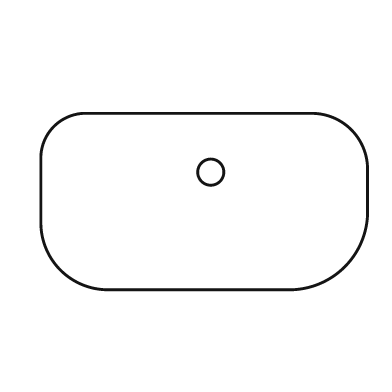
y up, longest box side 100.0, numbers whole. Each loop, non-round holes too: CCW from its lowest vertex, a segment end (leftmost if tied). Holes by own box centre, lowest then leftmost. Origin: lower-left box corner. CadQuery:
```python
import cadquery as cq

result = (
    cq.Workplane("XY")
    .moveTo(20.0, 0.0)
    .lineTo(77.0, 0.0)
    .threePointArc((93.0, 7.0), (100.0, 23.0))
    .lineTo(100.0, 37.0)
    .threePointArc((95.0, 49.0), (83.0, 54.0))
    .lineTo(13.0, 54.0)
    .threePointArc((4.0, 50.0), (0.0, 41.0))
    .lineTo(0.0, 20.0)
    .threePointArc((6.0, 6.0), (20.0, 0.0))
    .close()
    .moveTo(52.0, 36.0)
    .circle(4.0)
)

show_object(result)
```